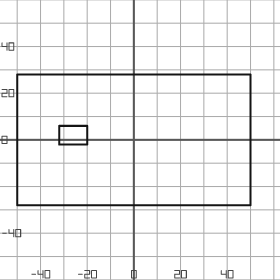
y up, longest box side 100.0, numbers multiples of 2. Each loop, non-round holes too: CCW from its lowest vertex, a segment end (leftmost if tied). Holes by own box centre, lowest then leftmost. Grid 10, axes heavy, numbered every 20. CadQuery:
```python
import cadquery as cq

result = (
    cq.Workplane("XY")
    .moveTo(-50.0, -28.0)
    .lineTo(50.0, -28.0)
    .lineTo(50.0, 28.0)
    .lineTo(-50.0, 28.0)
    .close()
    .moveTo(-32.0, -2.0)
    .lineTo(-20.0, -2.0)
    .lineTo(-20.0, 6.0)
    .lineTo(-32.0, 6.0)
    .close()
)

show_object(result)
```